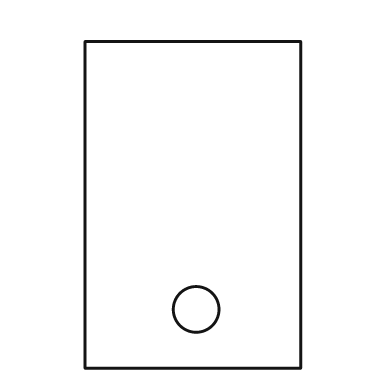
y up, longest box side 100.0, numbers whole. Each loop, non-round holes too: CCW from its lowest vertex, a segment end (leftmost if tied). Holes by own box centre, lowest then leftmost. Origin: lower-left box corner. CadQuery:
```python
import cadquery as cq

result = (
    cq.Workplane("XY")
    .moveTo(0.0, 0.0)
    .lineTo(66.0, 0.0)
    .lineTo(66.0, 100.0)
    .lineTo(0.0, 100.0)
    .close()
    .moveTo(34.0, 18.0)
    .circle(7.0)
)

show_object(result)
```